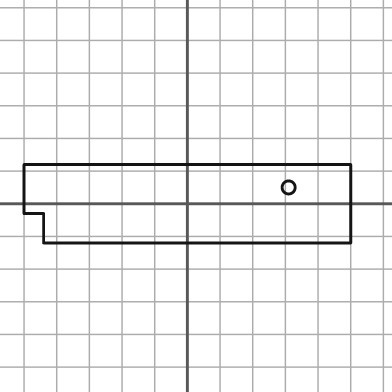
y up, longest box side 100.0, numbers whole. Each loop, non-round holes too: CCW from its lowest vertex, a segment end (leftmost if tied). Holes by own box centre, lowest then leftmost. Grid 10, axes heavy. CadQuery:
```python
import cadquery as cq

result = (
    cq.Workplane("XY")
    .moveTo(-44.0, -12.0)
    .lineTo(50.0, -12.0)
    .lineTo(50.0, 12.0)
    .lineTo(-50.0, 12.0)
    .lineTo(-50.0, -3.0)
    .lineTo(-44.0, -3.0)
    .close()
    .moveTo(31.0, 5.0)
    .circle(2.0)
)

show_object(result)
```